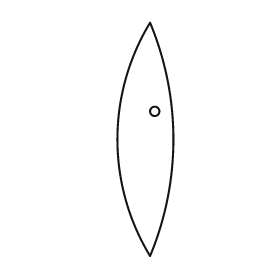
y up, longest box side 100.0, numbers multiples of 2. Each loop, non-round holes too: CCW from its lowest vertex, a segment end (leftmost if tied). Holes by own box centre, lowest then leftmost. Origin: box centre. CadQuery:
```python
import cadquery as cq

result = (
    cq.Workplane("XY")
    .moveTo(2.0, -50.0)
    .threePointArc((12.0, 0.0), (2.0, 50.0))
    .threePointArc((-12.0, 0.0), (2.0, -50.0))
    .close()
    .moveTo(4.0, 12.0)
    .circle(2.0)
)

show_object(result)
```